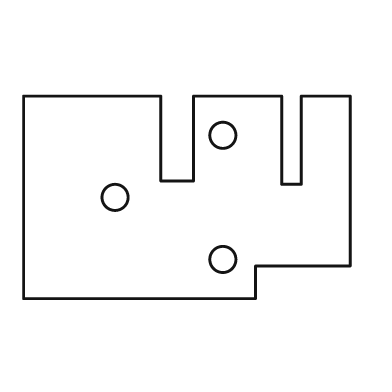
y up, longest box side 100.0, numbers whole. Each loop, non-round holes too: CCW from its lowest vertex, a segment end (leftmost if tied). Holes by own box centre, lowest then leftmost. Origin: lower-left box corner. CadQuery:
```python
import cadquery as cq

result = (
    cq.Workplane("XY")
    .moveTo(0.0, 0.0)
    .lineTo(71.0, 0.0)
    .lineTo(71.0, 10.0)
    .lineTo(100.0, 10.0)
    .lineTo(100.0, 62.0)
    .lineTo(85.0, 62.0)
    .lineTo(85.0, 35.0)
    .lineTo(79.0, 35.0)
    .lineTo(79.0, 62.0)
    .lineTo(52.0, 62.0)
    .lineTo(52.0, 36.0)
    .lineTo(42.0, 36.0)
    .lineTo(42.0, 62.0)
    .lineTo(0.0, 62.0)
    .close()
    .moveTo(61.0, 12.0)
    .circle(4.0)
    .moveTo(28.0, 31.0)
    .circle(4.0)
    .moveTo(61.0, 50.0)
    .circle(4.0)
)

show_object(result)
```